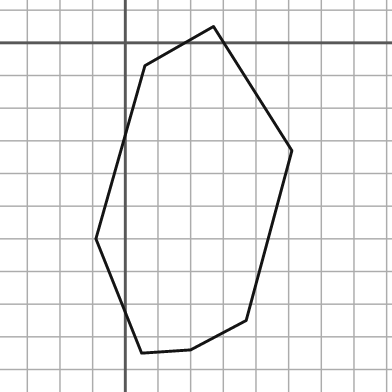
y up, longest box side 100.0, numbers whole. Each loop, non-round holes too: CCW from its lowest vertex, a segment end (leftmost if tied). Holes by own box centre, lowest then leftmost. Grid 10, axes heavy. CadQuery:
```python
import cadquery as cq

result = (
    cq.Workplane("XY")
    .moveTo(5.0, -95.0)
    .lineTo(20.0, -94.0)
    .lineTo(37.0, -85.0)
    .lineTo(51.0, -33.0)
    .lineTo(27.0, 5.0)
    .lineTo(6.0, -7.0)
    .lineTo(-9.0, -60.0)
    .close()
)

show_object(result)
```